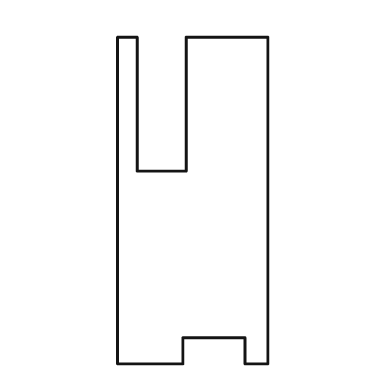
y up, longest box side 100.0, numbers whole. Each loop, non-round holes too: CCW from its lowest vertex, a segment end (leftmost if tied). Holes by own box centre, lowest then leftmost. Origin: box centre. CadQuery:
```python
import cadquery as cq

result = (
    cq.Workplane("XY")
    .moveTo(-23.0, -50.0)
    .lineTo(-3.0, -50.0)
    .lineTo(-3.0, -42.0)
    .lineTo(16.0, -42.0)
    .lineTo(16.0, -50.0)
    .lineTo(23.0, -50.0)
    .lineTo(23.0, 50.0)
    .lineTo(-2.0, 50.0)
    .lineTo(-2.0, 9.0)
    .lineTo(-17.0, 9.0)
    .lineTo(-17.0, 50.0)
    .lineTo(-23.0, 50.0)
    .close()
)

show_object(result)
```